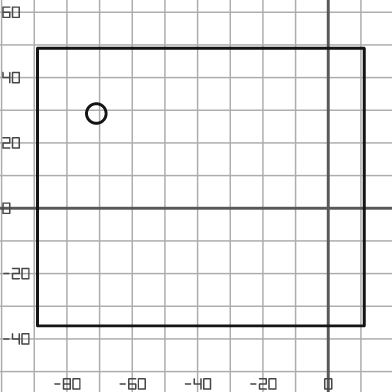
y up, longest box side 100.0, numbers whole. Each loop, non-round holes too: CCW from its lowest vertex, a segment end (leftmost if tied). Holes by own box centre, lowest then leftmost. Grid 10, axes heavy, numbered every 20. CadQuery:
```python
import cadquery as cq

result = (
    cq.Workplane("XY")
    .moveTo(-89.0, -36.0)
    .lineTo(11.0, -36.0)
    .lineTo(11.0, 49.0)
    .lineTo(-89.0, 49.0)
    .close()
    .moveTo(-71.0, 29.0)
    .circle(3.0)
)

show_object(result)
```